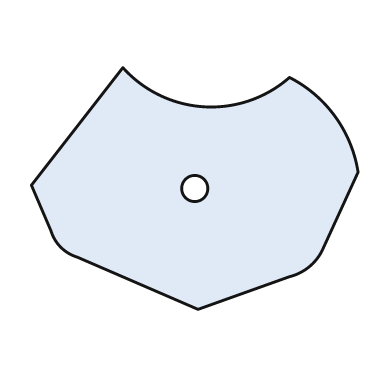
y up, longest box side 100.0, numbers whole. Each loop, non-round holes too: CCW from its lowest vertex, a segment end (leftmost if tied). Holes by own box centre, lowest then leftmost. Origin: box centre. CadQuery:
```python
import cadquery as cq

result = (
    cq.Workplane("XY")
    .moveTo(1.0, -37.0)
    .lineTo(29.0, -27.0)
    .threePointArc((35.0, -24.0), (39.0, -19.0))
    .lineTo(50.0, 5.0)
    .threePointArc((43.0, 22.0), (29.0, 34.0))
    .threePointArc((3.0, 25.0), (-22.0, 37.0))
    .lineTo(-50.0, 1.0)
    .lineTo(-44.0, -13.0)
    .threePointArc((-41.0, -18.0), (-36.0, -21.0))
    .close()
    .moveTo(0.0, 0.0)
    .circle(4.0)
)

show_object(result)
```